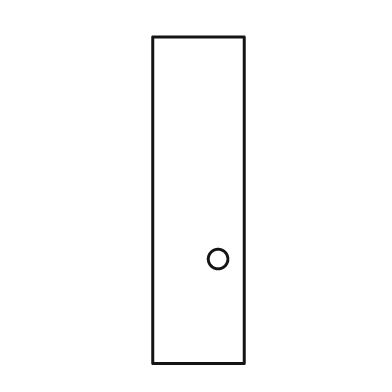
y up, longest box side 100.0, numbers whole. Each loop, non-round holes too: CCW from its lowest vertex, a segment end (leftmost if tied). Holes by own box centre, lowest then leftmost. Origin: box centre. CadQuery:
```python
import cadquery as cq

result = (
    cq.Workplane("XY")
    .moveTo(-14.0, -50.0)
    .lineTo(14.0, -50.0)
    .lineTo(14.0, 50.0)
    .lineTo(-14.0, 50.0)
    .close()
    .moveTo(6.0, -18.0)
    .circle(3.0)
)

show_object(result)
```